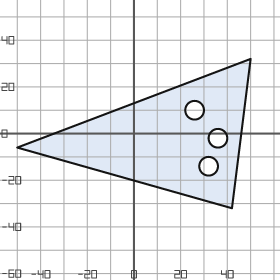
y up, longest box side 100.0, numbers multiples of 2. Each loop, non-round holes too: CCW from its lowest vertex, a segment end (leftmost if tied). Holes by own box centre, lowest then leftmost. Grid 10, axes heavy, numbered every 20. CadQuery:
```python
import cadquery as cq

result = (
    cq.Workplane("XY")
    .moveTo(42.0, -32.0)
    .lineTo(50.0, 32.0)
    .lineTo(-50.0, -6.0)
    .close()
    .moveTo(32.0, -14.0)
    .circle(4.0)
    .moveTo(36.0, -2.0)
    .circle(4.0)
    .moveTo(26.0, 10.0)
    .circle(4.0)
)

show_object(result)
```